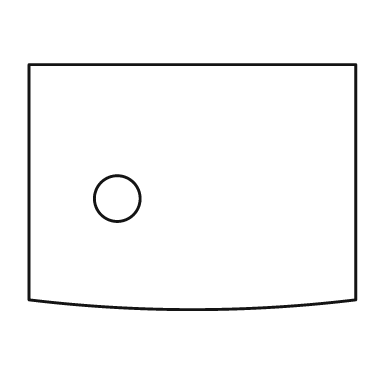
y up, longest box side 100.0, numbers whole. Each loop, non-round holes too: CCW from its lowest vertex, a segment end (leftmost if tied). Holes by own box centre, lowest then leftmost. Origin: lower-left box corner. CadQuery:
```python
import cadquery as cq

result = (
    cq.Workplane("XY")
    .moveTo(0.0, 3.0)
    .threePointArc((50.0, 0.0), (100.0, 3.0))
    .lineTo(100.0, 75.0)
    .lineTo(0.0, 75.0)
    .close()
    .moveTo(27.0, 34.0)
    .circle(7.0)
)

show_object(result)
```